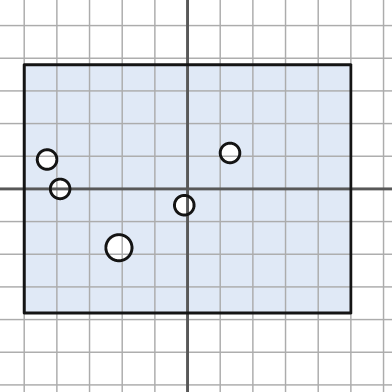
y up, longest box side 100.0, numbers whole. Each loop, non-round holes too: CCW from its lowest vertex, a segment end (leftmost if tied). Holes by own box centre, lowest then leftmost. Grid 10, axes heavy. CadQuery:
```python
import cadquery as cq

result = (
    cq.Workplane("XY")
    .moveTo(-50.0, -38.0)
    .lineTo(50.0, -38.0)
    .lineTo(50.0, 38.0)
    .lineTo(-50.0, 38.0)
    .close()
    .moveTo(-21.0, -18.0)
    .circle(4.0)
    .moveTo(-1.0, -5.0)
    .circle(3.0)
    .moveTo(-39.0, 0.0)
    .circle(3.0)
    .moveTo(-43.0, 9.0)
    .circle(3.0)
    .moveTo(13.0, 11.0)
    .circle(3.0)
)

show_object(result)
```